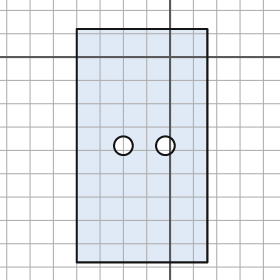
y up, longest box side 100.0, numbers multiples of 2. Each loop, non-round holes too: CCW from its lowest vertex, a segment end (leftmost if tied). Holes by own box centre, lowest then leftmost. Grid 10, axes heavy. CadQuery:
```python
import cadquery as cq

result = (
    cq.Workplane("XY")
    .moveTo(-40.0, -88.0)
    .lineTo(16.0, -88.0)
    .lineTo(16.0, 12.0)
    .lineTo(-40.0, 12.0)
    .close()
    .moveTo(-20.0, -38.0)
    .circle(4.0)
    .moveTo(-2.0, -38.0)
    .circle(4.0)
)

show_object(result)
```